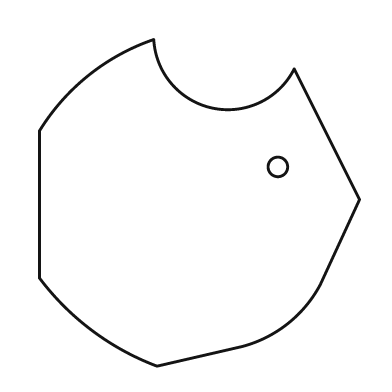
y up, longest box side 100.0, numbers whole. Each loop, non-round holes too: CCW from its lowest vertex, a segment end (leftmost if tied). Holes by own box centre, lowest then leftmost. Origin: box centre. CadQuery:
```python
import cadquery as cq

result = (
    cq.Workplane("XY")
    .moveTo(-13.0, -50.0)
    .lineTo(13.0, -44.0)
    .threePointArc((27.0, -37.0), (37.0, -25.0))
    .lineTo(49.0, 1.0)
    .lineTo(29.0, 41.0)
    .threePointArc((4.0, 29.0), (-14.0, 50.0))
    .threePointArc((-34.0, 39.0), (-49.0, 22.0))
    .lineTo(-49.0, -23.0)
    .threePointArc((-33.0, -39.0), (-13.0, -50.0))
    .close()
    .moveTo(24.0, 11.0)
    .circle(3.0)
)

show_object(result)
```